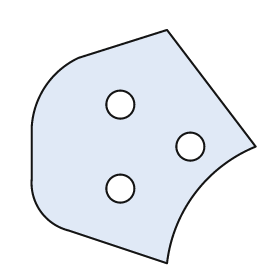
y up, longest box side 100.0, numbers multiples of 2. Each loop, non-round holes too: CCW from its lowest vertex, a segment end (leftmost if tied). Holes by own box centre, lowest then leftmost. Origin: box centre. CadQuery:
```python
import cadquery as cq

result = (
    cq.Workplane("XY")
    .moveTo(10.0, -50.0)
    .threePointArc((22.0, -20.0), (48.0, 0.0))
    .lineTo(10.0, 50.0)
    .lineTo(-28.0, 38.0)
    .threePointArc((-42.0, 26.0), (-48.0, 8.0))
    .lineTo(-48.0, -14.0)
    .threePointArc((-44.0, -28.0), (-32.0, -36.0))
    .close()
    .moveTo(-10.0, -18.0)
    .circle(6.0)
    .moveTo(20.0, 0.0)
    .circle(6.0)
    .moveTo(-10.0, 18.0)
    .circle(6.0)
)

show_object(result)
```